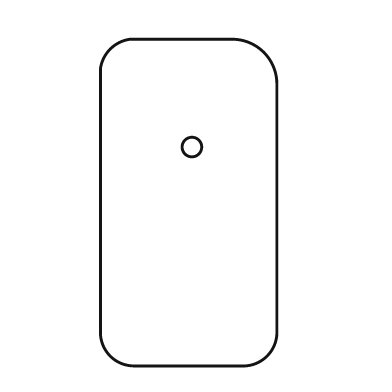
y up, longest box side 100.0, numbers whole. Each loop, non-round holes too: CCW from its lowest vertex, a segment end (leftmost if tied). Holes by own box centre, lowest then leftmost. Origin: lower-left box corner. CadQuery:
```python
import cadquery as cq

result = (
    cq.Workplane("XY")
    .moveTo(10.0, 0.0)
    .lineTo(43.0, 0.0)
    .threePointArc((51.0, 3.0), (54.0, 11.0))
    .lineTo(54.0, 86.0)
    .threePointArc((50.0, 96.0), (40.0, 100.0))
    .lineTo(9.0, 100.0)
    .threePointArc((3.0, 97.0), (0.0, 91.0))
    .lineTo(0.0, 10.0)
    .threePointArc((3.0, 3.0), (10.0, 0.0))
    .close()
    .moveTo(28.0, 67.0)
    .circle(3.0)
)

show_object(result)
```